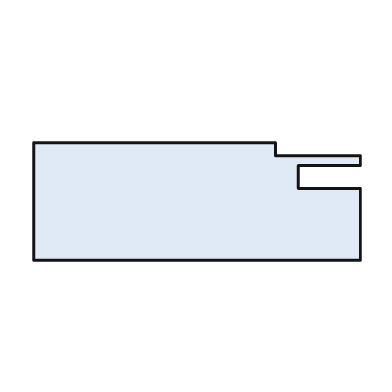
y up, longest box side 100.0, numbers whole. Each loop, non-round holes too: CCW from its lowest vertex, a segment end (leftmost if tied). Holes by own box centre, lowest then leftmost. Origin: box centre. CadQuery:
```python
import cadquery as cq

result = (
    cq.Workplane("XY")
    .moveTo(-50.0, -18.0)
    .lineTo(50.0, -18.0)
    .lineTo(50.0, 4.0)
    .lineTo(31.0, 4.0)
    .lineTo(31.0, 11.0)
    .lineTo(50.0, 11.0)
    .lineTo(50.0, 14.0)
    .lineTo(24.0, 14.0)
    .lineTo(24.0, 18.0)
    .lineTo(-50.0, 18.0)
    .close()
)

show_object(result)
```